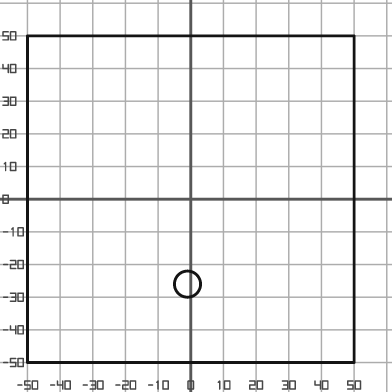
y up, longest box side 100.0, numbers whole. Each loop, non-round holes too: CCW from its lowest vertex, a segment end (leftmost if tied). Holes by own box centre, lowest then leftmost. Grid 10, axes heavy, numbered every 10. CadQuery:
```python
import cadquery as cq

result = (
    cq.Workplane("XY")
    .moveTo(-50.0, -50.0)
    .lineTo(50.0, -50.0)
    .lineTo(50.0, 50.0)
    .lineTo(-50.0, 50.0)
    .close()
    .moveTo(-1.0, -26.0)
    .circle(4.0)
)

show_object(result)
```